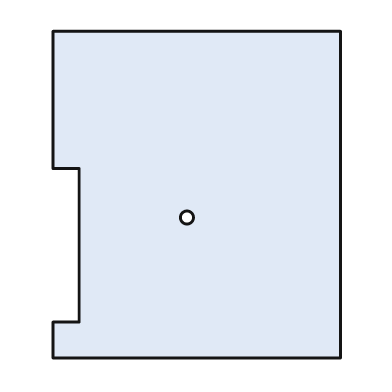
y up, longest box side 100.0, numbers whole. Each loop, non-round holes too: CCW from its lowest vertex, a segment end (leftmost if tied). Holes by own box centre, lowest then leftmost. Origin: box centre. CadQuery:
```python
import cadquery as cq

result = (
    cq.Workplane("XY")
    .moveTo(-44.0, -50.0)
    .lineTo(44.0, -50.0)
    .lineTo(44.0, 50.0)
    .lineTo(-44.0, 50.0)
    .lineTo(-44.0, 8.0)
    .lineTo(-36.0, 8.0)
    .lineTo(-36.0, -39.0)
    .lineTo(-44.0, -39.0)
    .close()
    .moveTo(-3.0, -7.0)
    .circle(2.0)
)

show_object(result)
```